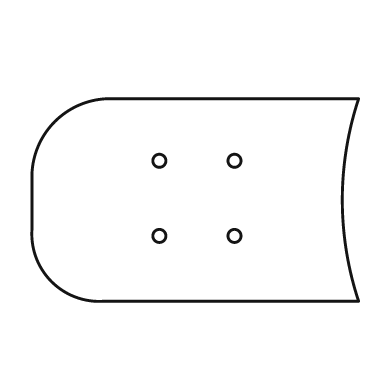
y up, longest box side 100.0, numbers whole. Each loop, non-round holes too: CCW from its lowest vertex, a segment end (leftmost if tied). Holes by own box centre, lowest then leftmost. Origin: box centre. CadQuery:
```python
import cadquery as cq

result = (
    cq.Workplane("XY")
    .moveTo(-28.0, -31.0)
    .lineTo(50.0, -31.0)
    .threePointArc((45.0, 0.0), (50.0, 31.0))
    .lineTo(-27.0, 31.0)
    .threePointArc((-43.0, 24.0), (-50.0, 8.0))
    .lineTo(-50.0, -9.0)
    .threePointArc((-44.0, -25.0), (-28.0, -31.0))
    .close()
    .moveTo(-11.0, -11.0)
    .circle(2.0)
    .moveTo(12.0, -11.0)
    .circle(2.0)
    .moveTo(-11.0, 12.0)
    .circle(2.0)
    .moveTo(12.0, 12.0)
    .circle(2.0)
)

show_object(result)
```